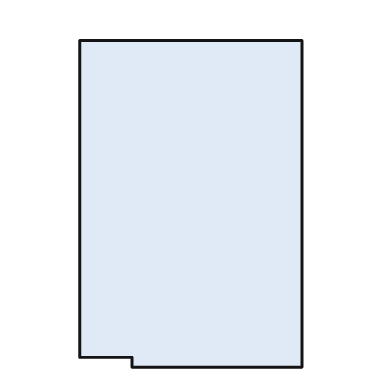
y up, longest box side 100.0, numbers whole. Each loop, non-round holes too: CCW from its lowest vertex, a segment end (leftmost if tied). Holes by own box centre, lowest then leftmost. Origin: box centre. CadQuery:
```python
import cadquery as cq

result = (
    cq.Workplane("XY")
    .moveTo(-18.0, -50.0)
    .lineTo(34.0, -50.0)
    .lineTo(34.0, 50.0)
    .lineTo(-34.0, 50.0)
    .lineTo(-34.0, -47.0)
    .lineTo(-18.0, -47.0)
    .close()
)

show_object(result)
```